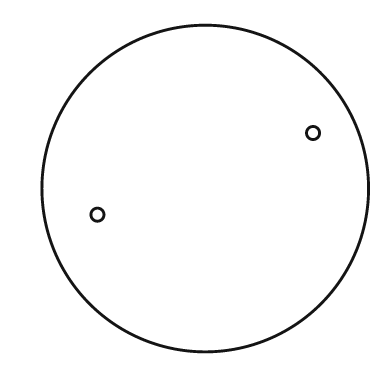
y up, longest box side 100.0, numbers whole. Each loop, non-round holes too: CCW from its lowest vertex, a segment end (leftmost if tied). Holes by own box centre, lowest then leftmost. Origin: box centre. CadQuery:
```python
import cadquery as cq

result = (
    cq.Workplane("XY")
    .moveTo(0.0, 0.0)
    .circle(50.0)
    .moveTo(-33.0, -8.0)
    .circle(2.0)
    .moveTo(33.0, 17.0)
    .circle(2.0)
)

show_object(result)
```